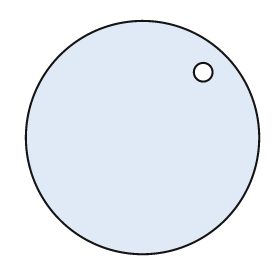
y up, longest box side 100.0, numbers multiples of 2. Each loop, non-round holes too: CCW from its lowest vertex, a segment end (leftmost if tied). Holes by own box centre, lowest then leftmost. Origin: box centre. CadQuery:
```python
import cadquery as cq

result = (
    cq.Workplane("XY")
    .moveTo(0.0, 0.0)
    .circle(50.0)
    .moveTo(26.0, 28.0)
    .circle(4.0)
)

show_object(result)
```